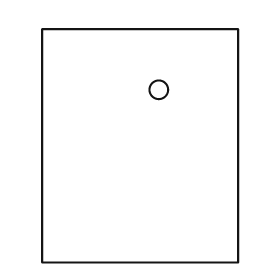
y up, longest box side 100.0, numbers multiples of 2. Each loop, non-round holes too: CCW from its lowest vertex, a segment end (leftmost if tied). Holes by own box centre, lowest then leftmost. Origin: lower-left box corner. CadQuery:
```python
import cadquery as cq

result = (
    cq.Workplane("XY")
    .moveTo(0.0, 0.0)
    .lineTo(84.0, 0.0)
    .lineTo(84.0, 100.0)
    .lineTo(0.0, 100.0)
    .close()
    .moveTo(50.0, 74.0)
    .circle(4.0)
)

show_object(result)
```